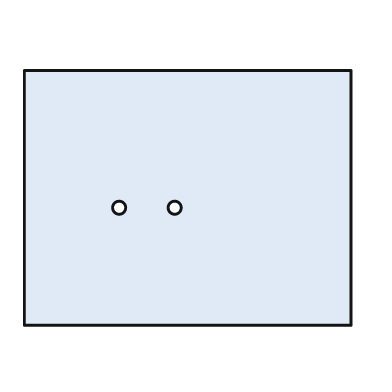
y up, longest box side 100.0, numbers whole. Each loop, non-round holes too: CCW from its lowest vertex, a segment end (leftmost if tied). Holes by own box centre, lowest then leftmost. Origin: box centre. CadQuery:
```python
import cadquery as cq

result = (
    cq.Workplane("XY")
    .moveTo(-50.0, -39.0)
    .lineTo(50.0, -39.0)
    .lineTo(50.0, 39.0)
    .lineTo(-50.0, 39.0)
    .close()
    .moveTo(-21.0, -3.0)
    .circle(2.0)
    .moveTo(-4.0, -3.0)
    .circle(2.0)
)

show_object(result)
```